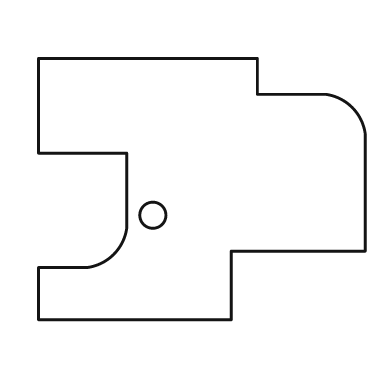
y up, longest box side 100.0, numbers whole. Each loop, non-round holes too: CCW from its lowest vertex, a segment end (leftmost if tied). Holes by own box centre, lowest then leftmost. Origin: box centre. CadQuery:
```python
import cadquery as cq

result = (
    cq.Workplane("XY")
    .moveTo(-50.0, -40.0)
    .lineTo(9.0, -40.0)
    .lineTo(9.0, -19.0)
    .lineTo(50.0, -19.0)
    .lineTo(50.0, 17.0)
    .threePointArc((46.0, 25.0), (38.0, 29.0))
    .lineTo(17.0, 29.0)
    .lineTo(17.0, 40.0)
    .lineTo(-50.0, 40.0)
    .lineTo(-50.0, 11.0)
    .lineTo(-23.0, 11.0)
    .lineTo(-23.0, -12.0)
    .threePointArc((-27.0, -20.0), (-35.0, -24.0))
    .lineTo(-50.0, -24.0)
    .close()
    .moveTo(-15.0, -8.0)
    .circle(4.0)
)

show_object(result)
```